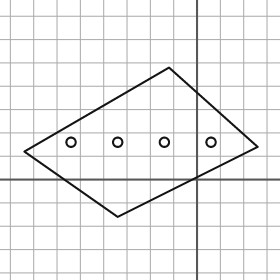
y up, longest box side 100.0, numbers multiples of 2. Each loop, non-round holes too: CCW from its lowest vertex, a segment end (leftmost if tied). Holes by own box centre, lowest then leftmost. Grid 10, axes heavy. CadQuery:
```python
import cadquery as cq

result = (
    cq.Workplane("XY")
    .moveTo(-34.0, -16.0)
    .lineTo(26.0, 14.0)
    .lineTo(-12.0, 48.0)
    .lineTo(-74.0, 12.0)
    .close()
    .moveTo(-54.0, 16.0)
    .circle(2.0)
    .moveTo(-34.0, 16.0)
    .circle(2.0)
    .moveTo(-14.0, 16.0)
    .circle(2.0)
    .moveTo(6.0, 16.0)
    .circle(2.0)
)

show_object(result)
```